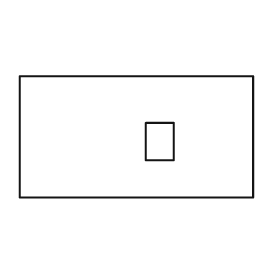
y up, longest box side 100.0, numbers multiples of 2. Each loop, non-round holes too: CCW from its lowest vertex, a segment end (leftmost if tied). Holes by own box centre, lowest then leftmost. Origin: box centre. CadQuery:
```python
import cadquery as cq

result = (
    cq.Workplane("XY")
    .moveTo(-50.0, -26.0)
    .lineTo(50.0, -26.0)
    .lineTo(50.0, 26.0)
    .lineTo(-50.0, 26.0)
    .close()
    .moveTo(4.0, -10.0)
    .lineTo(16.0, -10.0)
    .lineTo(16.0, 6.0)
    .lineTo(4.0, 6.0)
    .close()
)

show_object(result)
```